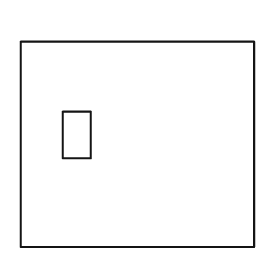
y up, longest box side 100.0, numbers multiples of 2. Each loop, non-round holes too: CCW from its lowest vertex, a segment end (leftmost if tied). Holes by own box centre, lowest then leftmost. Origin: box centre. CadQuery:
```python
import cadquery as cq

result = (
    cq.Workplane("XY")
    .moveTo(-50.0, -44.0)
    .lineTo(50.0, -44.0)
    .lineTo(50.0, 44.0)
    .lineTo(-50.0, 44.0)
    .close()
    .moveTo(-32.0, -6.0)
    .lineTo(-20.0, -6.0)
    .lineTo(-20.0, 14.0)
    .lineTo(-32.0, 14.0)
    .close()
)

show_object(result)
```